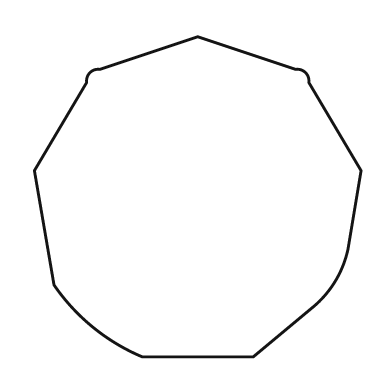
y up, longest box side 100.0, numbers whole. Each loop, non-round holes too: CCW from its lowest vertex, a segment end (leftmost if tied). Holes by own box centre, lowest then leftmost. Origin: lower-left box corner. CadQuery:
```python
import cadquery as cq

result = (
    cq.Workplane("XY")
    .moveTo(33.0, 0.0)
    .lineTo(67.0, 0.0)
    .lineTo(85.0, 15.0)
    .threePointArc((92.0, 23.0), (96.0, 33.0))
    .lineTo(100.0, 57.0)
    .lineTo(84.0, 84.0)
    .threePointArc((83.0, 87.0), (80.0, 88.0))
    .lineTo(50.0, 98.0)
    .lineTo(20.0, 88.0)
    .threePointArc((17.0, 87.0), (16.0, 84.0))
    .lineTo(0.0, 57.0)
    .lineTo(6.0, 22.0)
    .threePointArc((18.0, 9.0), (33.0, 0.0))
    .close()
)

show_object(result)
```